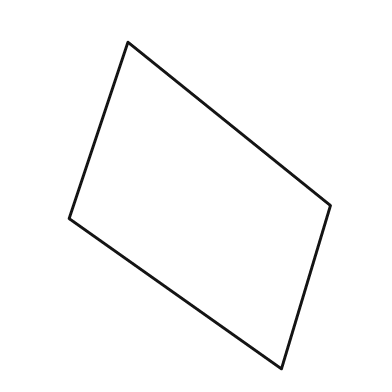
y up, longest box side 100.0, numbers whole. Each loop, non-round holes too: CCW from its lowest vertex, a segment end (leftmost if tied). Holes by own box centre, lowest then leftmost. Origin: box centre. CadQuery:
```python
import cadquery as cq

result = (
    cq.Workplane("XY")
    .moveTo(25.0, -50.0)
    .lineTo(40.0, 0.0)
    .lineTo(-22.0, 50.0)
    .lineTo(-40.0, -4.0)
    .close()
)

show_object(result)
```